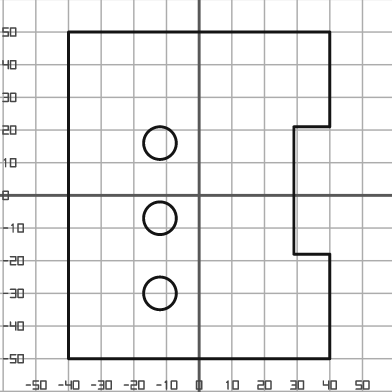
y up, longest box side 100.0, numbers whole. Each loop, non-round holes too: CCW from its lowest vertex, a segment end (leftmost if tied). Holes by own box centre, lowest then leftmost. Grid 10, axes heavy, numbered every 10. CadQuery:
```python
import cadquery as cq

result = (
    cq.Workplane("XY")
    .moveTo(-40.0, -50.0)
    .lineTo(40.0, -50.0)
    .lineTo(40.0, -18.0)
    .lineTo(29.0, -18.0)
    .lineTo(29.0, 21.0)
    .lineTo(40.0, 21.0)
    .lineTo(40.0, 50.0)
    .lineTo(-40.0, 50.0)
    .close()
    .moveTo(-12.0, -30.0)
    .circle(5.0)
    .moveTo(-12.0, -7.0)
    .circle(5.0)
    .moveTo(-12.0, 16.0)
    .circle(5.0)
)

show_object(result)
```